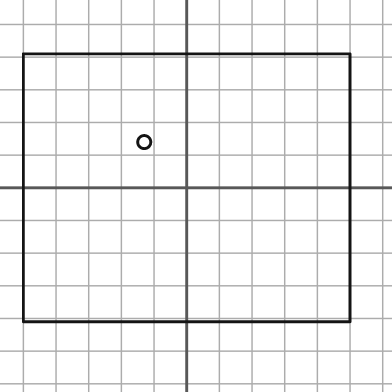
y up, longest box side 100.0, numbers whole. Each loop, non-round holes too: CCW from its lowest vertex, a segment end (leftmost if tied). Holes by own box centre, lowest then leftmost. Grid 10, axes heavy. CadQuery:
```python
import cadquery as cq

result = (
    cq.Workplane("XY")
    .moveTo(-50.0, -41.0)
    .lineTo(50.0, -41.0)
    .lineTo(50.0, 41.0)
    .lineTo(-50.0, 41.0)
    .close()
    .moveTo(-13.0, 14.0)
    .circle(2.0)
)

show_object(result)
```